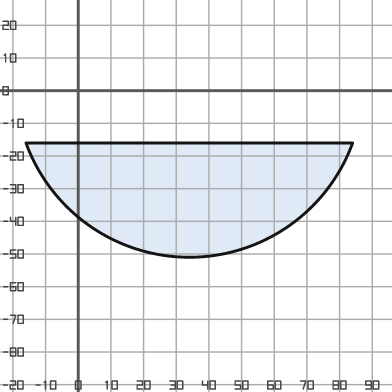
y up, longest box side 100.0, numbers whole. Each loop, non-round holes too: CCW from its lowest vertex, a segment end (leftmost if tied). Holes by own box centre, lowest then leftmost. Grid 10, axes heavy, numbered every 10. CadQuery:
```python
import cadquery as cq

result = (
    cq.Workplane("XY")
    .moveTo(-16.0, -16.0)
    .threePointArc((34.0, -51.0), (84.0, -16.0))
    .close()
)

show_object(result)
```